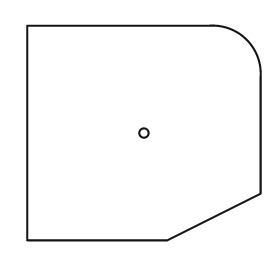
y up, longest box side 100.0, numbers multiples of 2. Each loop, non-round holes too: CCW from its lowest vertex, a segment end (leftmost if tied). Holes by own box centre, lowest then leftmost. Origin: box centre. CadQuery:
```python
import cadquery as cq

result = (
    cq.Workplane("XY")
    .moveTo(-50.0, -46.0)
    .lineTo(10.0, -46.0)
    .lineTo(50.0, -26.0)
    .lineTo(50.0, 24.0)
    .threePointArc((44.0, 40.0), (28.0, 46.0))
    .lineTo(-50.0, 46.0)
    .close()
    .moveTo(0.0, 0.0)
    .circle(2.0)
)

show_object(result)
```